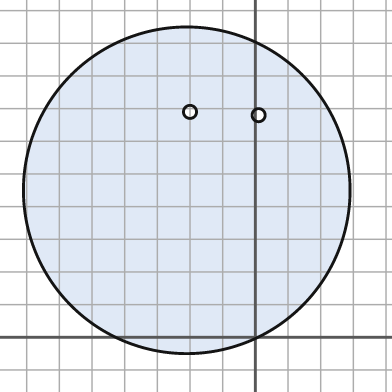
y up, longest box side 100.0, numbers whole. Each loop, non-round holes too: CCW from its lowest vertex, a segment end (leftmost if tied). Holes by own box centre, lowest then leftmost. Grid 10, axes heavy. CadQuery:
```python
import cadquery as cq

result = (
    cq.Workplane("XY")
    .moveTo(-21.0, 45.0)
    .circle(50.0)
    .moveTo(1.0, 68.0)
    .circle(2.0)
    .moveTo(-20.0, 69.0)
    .circle(2.0)
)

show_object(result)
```